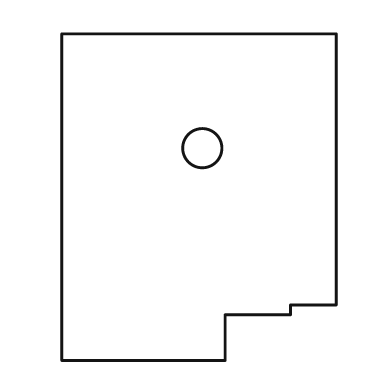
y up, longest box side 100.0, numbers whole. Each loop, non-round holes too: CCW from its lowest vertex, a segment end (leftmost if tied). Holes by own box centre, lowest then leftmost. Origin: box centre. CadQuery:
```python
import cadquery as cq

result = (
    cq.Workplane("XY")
    .moveTo(-42.0, -50.0)
    .lineTo(8.0, -50.0)
    .lineTo(8.0, -36.0)
    .lineTo(28.0, -36.0)
    .lineTo(28.0, -33.0)
    .lineTo(42.0, -33.0)
    .lineTo(42.0, 50.0)
    .lineTo(-42.0, 50.0)
    .close()
    .moveTo(1.0, 15.0)
    .circle(6.0)
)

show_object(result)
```